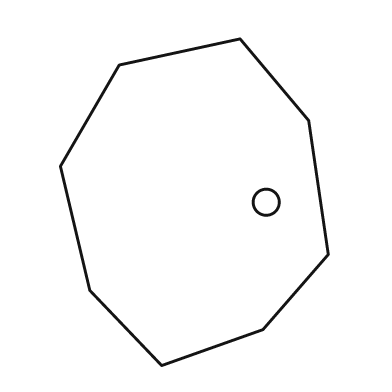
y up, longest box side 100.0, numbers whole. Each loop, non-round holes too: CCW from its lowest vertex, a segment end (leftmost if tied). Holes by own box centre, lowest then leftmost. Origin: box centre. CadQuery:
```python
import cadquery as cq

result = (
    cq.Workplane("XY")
    .moveTo(-10.0, -50.0)
    .lineTo(21.0, -39.0)
    .lineTo(41.0, -16.0)
    .lineTo(35.0, 25.0)
    .lineTo(14.0, 50.0)
    .lineTo(-23.0, 42.0)
    .lineTo(-41.0, 11.0)
    .lineTo(-32.0, -27.0)
    .close()
    .moveTo(22.0, 0.0)
    .circle(4.0)
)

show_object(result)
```